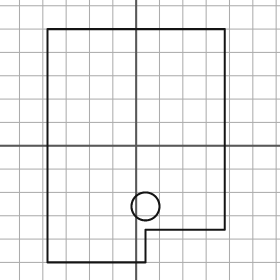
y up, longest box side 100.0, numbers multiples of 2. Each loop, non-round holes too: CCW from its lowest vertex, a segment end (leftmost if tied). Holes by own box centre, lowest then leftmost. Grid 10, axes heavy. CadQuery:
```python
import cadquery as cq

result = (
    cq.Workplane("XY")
    .moveTo(-38.0, -50.0)
    .lineTo(4.0, -50.0)
    .lineTo(4.0, -36.0)
    .lineTo(38.0, -36.0)
    .lineTo(38.0, 50.0)
    .lineTo(-38.0, 50.0)
    .close()
    .moveTo(4.0, -26.0)
    .circle(6.0)
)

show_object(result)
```